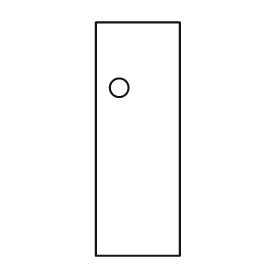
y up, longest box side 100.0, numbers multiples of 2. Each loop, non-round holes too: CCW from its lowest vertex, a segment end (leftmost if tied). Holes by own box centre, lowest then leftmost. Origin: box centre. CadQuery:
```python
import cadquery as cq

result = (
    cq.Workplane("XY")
    .moveTo(-18.0, -50.0)
    .lineTo(18.0, -50.0)
    .lineTo(18.0, 50.0)
    .lineTo(-18.0, 50.0)
    .close()
    .moveTo(-8.0, 22.0)
    .circle(4.0)
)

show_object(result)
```